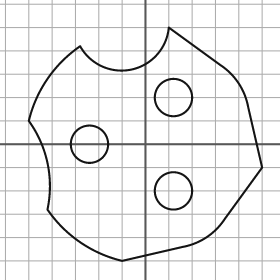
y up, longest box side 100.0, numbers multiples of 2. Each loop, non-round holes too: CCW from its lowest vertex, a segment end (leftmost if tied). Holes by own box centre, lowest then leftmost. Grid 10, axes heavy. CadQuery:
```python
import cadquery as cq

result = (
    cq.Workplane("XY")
    .moveTo(-10.0, -50.0)
    .lineTo(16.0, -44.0)
    .threePointArc((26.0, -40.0), (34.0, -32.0))
    .lineTo(50.0, -10.0)
    .lineTo(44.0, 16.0)
    .threePointArc((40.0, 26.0), (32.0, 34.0))
    .lineTo(10.0, 50.0)
    .threePointArc((-6.0, 32.0), (-28.0, 42.0))
    .threePointArc((-42.0, 28.0), (-50.0, 10.0))
    .threePointArc((-42.0, -8.0), (-42.0, -28.0))
    .threePointArc((-28.0, -42.0), (-10.0, -50.0))
    .close()
    .moveTo(12.0, -20.0)
    .circle(8.0)
    .moveTo(-24.0, 0.0)
    .circle(8.0)
    .moveTo(12.0, 20.0)
    .circle(8.0)
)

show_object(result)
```